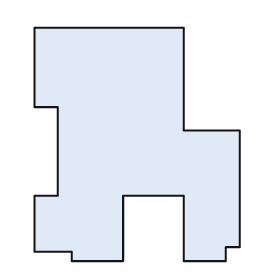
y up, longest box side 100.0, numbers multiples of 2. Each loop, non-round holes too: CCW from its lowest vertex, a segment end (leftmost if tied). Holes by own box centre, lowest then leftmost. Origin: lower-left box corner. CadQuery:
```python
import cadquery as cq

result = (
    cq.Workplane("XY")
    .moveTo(16.0, 0.0)
    .lineTo(38.0, 0.0)
    .lineTo(38.0, 28.0)
    .lineTo(64.0, 28.0)
    .lineTo(64.0, 0.0)
    .lineTo(82.0, 0.0)
    .lineTo(82.0, 6.0)
    .lineTo(88.0, 6.0)
    .lineTo(88.0, 56.0)
    .lineTo(64.0, 56.0)
    .lineTo(64.0, 100.0)
    .lineTo(0.0, 100.0)
    .lineTo(0.0, 66.0)
    .lineTo(10.0, 66.0)
    .lineTo(10.0, 28.0)
    .lineTo(0.0, 28.0)
    .lineTo(0.0, 4.0)
    .lineTo(16.0, 4.0)
    .close()
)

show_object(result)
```